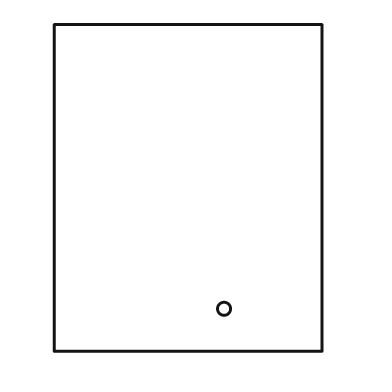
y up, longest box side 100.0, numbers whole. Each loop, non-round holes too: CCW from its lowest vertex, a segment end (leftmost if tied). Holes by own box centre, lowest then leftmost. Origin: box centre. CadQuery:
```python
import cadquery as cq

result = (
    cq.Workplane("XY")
    .moveTo(-41.0, -50.0)
    .lineTo(41.0, -50.0)
    .lineTo(41.0, 50.0)
    .lineTo(-41.0, 50.0)
    .close()
    .moveTo(11.0, -37.0)
    .circle(2.0)
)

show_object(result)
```